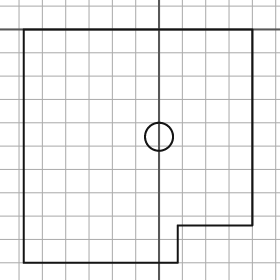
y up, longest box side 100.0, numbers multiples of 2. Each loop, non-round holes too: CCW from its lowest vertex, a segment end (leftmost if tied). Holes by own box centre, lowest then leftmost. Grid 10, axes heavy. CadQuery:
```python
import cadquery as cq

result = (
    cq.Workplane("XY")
    .moveTo(-58.0, -100.0)
    .lineTo(8.0, -100.0)
    .lineTo(8.0, -84.0)
    .lineTo(40.0, -84.0)
    .lineTo(40.0, 0.0)
    .lineTo(-58.0, 0.0)
    .close()
    .moveTo(0.0, -46.0)
    .circle(6.0)
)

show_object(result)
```